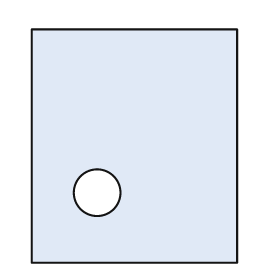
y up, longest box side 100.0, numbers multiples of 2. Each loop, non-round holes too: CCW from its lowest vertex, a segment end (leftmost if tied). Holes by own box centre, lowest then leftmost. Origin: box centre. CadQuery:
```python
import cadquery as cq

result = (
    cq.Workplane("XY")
    .moveTo(-44.0, -50.0)
    .lineTo(44.0, -50.0)
    .lineTo(44.0, 50.0)
    .lineTo(-44.0, 50.0)
    .close()
    .moveTo(-16.0, -20.0)
    .circle(10.0)
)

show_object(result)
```